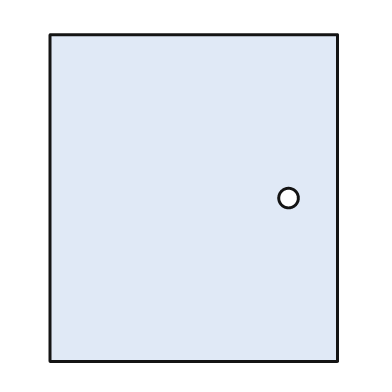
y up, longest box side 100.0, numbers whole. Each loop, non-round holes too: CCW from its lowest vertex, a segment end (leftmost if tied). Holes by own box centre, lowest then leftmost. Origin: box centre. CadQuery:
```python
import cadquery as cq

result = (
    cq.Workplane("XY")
    .moveTo(-44.0, -50.0)
    .lineTo(44.0, -50.0)
    .lineTo(44.0, 50.0)
    .lineTo(-44.0, 50.0)
    .close()
    .moveTo(29.0, 0.0)
    .circle(3.0)
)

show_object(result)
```